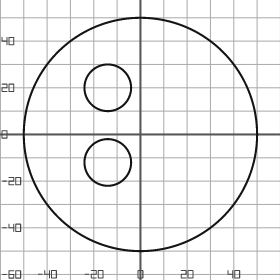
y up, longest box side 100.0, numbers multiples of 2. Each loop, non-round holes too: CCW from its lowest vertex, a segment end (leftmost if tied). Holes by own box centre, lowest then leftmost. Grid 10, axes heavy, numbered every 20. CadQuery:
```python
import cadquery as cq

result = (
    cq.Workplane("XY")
    .moveTo(0.0, 0.0)
    .circle(50.0)
    .moveTo(-14.0, -12.0)
    .circle(10.0)
    .moveTo(-14.0, 20.0)
    .circle(10.0)
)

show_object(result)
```